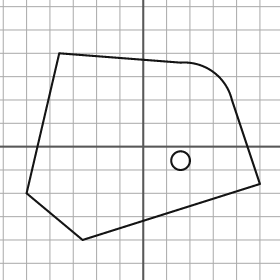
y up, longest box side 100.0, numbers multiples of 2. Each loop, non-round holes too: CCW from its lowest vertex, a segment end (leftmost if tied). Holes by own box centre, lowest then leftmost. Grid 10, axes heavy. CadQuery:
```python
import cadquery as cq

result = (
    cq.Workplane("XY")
    .moveTo(-26.0, -40.0)
    .lineTo(50.0, -16.0)
    .lineTo(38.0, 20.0)
    .threePointArc((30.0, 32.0), (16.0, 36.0))
    .lineTo(-36.0, 40.0)
    .lineTo(-50.0, -20.0)
    .close()
    .moveTo(16.0, -6.0)
    .circle(4.0)
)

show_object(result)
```